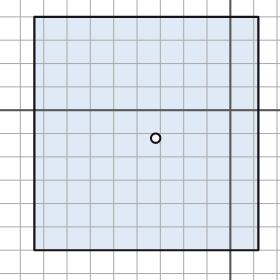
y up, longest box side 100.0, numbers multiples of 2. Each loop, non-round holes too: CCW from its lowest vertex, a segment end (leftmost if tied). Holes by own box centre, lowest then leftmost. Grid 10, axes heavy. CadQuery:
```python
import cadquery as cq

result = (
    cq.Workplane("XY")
    .moveTo(-84.0, -60.0)
    .lineTo(12.0, -60.0)
    .lineTo(12.0, 40.0)
    .lineTo(-84.0, 40.0)
    .close()
    .moveTo(-32.0, -12.0)
    .circle(2.0)
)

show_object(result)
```